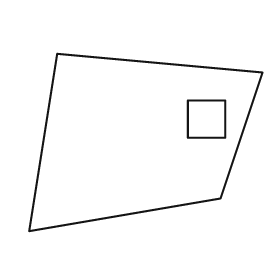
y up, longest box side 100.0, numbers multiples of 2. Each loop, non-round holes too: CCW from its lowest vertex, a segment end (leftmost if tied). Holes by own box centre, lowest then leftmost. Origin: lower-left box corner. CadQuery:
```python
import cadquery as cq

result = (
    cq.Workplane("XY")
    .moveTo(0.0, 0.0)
    .lineTo(82.0, 14.0)
    .lineTo(100.0, 68.0)
    .lineTo(12.0, 76.0)
    .close()
    .moveTo(68.0, 40.0)
    .lineTo(84.0, 40.0)
    .lineTo(84.0, 56.0)
    .lineTo(68.0, 56.0)
    .close()
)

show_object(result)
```